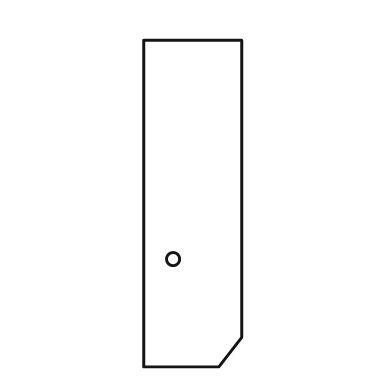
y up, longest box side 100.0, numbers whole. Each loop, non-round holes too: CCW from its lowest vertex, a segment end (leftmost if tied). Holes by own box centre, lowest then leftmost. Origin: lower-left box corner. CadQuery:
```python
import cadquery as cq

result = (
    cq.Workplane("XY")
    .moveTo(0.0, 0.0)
    .lineTo(23.0, 0.0)
    .lineTo(30.0, 9.0)
    .lineTo(30.0, 100.0)
    .lineTo(0.0, 100.0)
    .close()
    .moveTo(9.0, 33.0)
    .circle(2.0)
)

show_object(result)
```